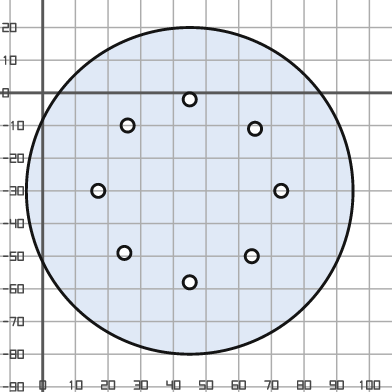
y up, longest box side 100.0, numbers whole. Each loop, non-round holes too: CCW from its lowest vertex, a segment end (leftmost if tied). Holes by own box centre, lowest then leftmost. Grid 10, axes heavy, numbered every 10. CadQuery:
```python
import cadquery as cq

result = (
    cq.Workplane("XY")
    .moveTo(45.0, -30.0)
    .circle(50.0)
    .moveTo(45.0, -58.0)
    .circle(2.0)
    .moveTo(64.0, -50.0)
    .circle(2.0)
    .moveTo(25.0, -49.0)
    .circle(2.0)
    .moveTo(17.0, -30.0)
    .circle(2.0)
    .moveTo(73.0, -30.0)
    .circle(2.0)
    .moveTo(65.0, -11.0)
    .circle(2.0)
    .moveTo(26.0, -10.0)
    .circle(2.0)
    .moveTo(45.0, -2.0)
    .circle(2.0)
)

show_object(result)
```